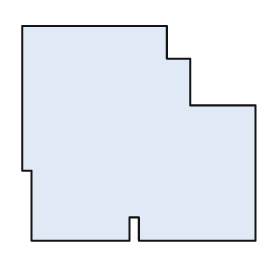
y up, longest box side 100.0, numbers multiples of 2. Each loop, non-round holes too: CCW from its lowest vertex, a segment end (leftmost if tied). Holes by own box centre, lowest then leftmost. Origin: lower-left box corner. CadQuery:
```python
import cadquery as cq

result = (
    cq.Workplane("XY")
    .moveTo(4.0, 0.0)
    .lineTo(46.0, 0.0)
    .lineTo(46.0, 10.0)
    .lineTo(50.0, 10.0)
    .lineTo(50.0, 0.0)
    .lineTo(100.0, 0.0)
    .lineTo(100.0, 58.0)
    .lineTo(72.0, 58.0)
    .lineTo(72.0, 78.0)
    .lineTo(62.0, 78.0)
    .lineTo(62.0, 92.0)
    .lineTo(0.0, 92.0)
    .lineTo(0.0, 30.0)
    .lineTo(4.0, 30.0)
    .close()
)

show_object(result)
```